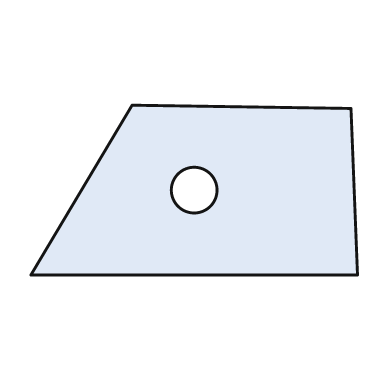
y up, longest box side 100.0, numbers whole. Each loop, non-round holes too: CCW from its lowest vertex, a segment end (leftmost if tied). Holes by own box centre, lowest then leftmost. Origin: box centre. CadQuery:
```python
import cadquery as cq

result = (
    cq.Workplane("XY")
    .moveTo(-50.0, -26.0)
    .lineTo(50.0, -26.0)
    .lineTo(48.0, 25.0)
    .lineTo(-19.0, 26.0)
    .close()
    .moveTo(0.0, 0.0)
    .circle(7.0)
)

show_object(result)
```